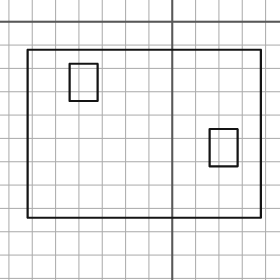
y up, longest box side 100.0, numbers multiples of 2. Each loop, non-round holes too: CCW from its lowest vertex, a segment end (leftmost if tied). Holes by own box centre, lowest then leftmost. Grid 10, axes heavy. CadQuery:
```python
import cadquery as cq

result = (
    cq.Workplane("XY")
    .moveTo(-62.0, -84.0)
    .lineTo(38.0, -84.0)
    .lineTo(38.0, -12.0)
    .lineTo(-62.0, -12.0)
    .close()
    .moveTo(16.0, -62.0)
    .lineTo(28.0, -62.0)
    .lineTo(28.0, -46.0)
    .lineTo(16.0, -46.0)
    .close()
    .moveTo(-44.0, -34.0)
    .lineTo(-32.0, -34.0)
    .lineTo(-32.0, -18.0)
    .lineTo(-44.0, -18.0)
    .close()
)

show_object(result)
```